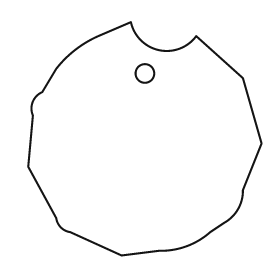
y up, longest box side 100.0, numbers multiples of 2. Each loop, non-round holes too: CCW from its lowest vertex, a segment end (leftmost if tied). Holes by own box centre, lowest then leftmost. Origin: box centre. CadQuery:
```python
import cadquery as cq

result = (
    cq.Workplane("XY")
    .moveTo(-10.0, -50.0)
    .lineTo(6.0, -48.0)
    .threePointArc((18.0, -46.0), (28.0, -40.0))
    .lineTo(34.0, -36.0)
    .threePointArc((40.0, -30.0), (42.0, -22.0))
    .lineTo(50.0, -2.0)
    .lineTo(42.0, 26.0)
    .lineTo(22.0, 44.0)
    .threePointArc((6.0, 38.0), (-6.0, 50.0))
    .lineTo(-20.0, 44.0)
    .threePointArc((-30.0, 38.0), (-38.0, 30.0))
    .lineTo(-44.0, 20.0)
    .threePointArc((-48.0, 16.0), (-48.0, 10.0))
    .lineTo(-50.0, -12.0)
    .lineTo(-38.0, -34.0)
    .threePointArc((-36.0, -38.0), (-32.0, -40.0))
    .close()
    .moveTo(0.0, 28.0)
    .circle(4.0)
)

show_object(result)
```